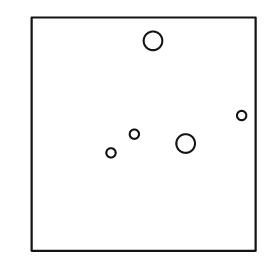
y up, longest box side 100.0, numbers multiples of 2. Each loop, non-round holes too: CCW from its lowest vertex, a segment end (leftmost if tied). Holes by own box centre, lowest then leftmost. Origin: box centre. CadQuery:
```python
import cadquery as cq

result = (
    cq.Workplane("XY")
    .moveTo(-48.0, -50.0)
    .lineTo(48.0, -50.0)
    .lineTo(48.0, 50.0)
    .lineTo(-48.0, 50.0)
    .close()
    .moveTo(-14.0, -8.0)
    .circle(2.0)
    .moveTo(18.0, -4.0)
    .circle(4.0)
    .moveTo(-4.0, 0.0)
    .circle(2.0)
    .moveTo(42.0, 8.0)
    .circle(2.0)
    .moveTo(4.0, 40.0)
    .circle(4.0)
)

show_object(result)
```